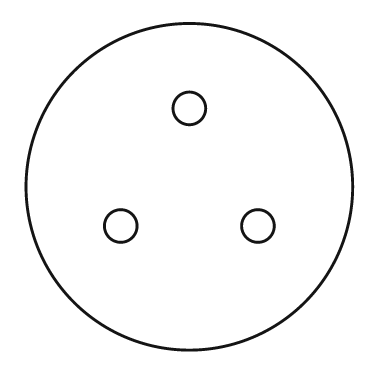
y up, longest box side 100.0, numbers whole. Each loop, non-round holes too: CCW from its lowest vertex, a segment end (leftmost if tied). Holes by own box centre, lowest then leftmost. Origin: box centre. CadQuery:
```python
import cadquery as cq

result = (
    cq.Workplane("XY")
    .moveTo(0.0, 0.0)
    .circle(50.0)
    .moveTo(-21.0, -12.0)
    .circle(5.0)
    .moveTo(21.0, -12.0)
    .circle(5.0)
    .moveTo(0.0, 24.0)
    .circle(5.0)
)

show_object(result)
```